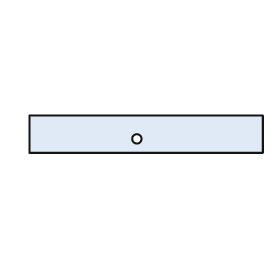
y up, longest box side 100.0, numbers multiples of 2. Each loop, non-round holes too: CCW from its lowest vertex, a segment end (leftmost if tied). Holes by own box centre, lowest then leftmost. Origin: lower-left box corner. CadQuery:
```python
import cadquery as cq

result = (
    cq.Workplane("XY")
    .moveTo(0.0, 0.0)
    .lineTo(100.0, 0.0)
    .lineTo(100.0, 16.0)
    .lineTo(0.0, 16.0)
    .close()
    .moveTo(46.0, 6.0)
    .circle(2.0)
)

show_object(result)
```